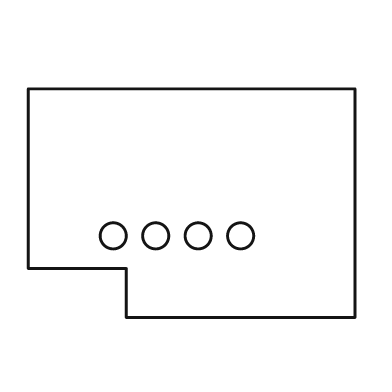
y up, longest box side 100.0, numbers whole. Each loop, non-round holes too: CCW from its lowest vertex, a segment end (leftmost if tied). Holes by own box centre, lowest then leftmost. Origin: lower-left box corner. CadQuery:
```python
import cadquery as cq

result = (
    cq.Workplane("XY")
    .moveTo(30.0, 0.0)
    .lineTo(100.0, 0.0)
    .lineTo(100.0, 70.0)
    .lineTo(0.0, 70.0)
    .lineTo(0.0, 15.0)
    .lineTo(30.0, 15.0)
    .close()
    .moveTo(26.0, 25.0)
    .circle(4.0)
    .moveTo(39.0, 25.0)
    .circle(4.0)
    .moveTo(52.0, 25.0)
    .circle(4.0)
    .moveTo(65.0, 25.0)
    .circle(4.0)
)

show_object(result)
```